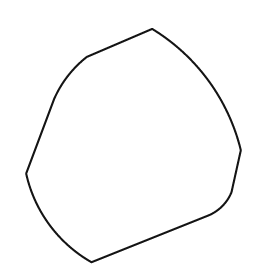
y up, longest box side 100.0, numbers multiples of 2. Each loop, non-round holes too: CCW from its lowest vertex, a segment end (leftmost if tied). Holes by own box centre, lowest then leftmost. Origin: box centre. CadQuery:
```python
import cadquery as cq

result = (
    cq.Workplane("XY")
    .moveTo(-18.0, -50.0)
    .lineTo(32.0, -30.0)
    .threePointArc((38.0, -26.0), (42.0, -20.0))
    .lineTo(46.0, -2.0)
    .threePointArc((32.0, 28.0), (8.0, 50.0))
    .lineTo(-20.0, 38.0)
    .threePointArc((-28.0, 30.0), (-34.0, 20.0))
    .lineTo(-46.0, -12.0)
    .threePointArc((-36.0, -34.0), (-18.0, -50.0))
    .close()
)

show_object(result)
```